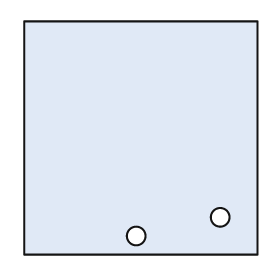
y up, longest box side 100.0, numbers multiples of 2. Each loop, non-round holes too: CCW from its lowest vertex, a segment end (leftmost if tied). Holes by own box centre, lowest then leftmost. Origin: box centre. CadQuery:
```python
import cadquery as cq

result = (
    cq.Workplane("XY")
    .moveTo(-50.0, -50.0)
    .lineTo(50.0, -50.0)
    .lineTo(50.0, 50.0)
    .lineTo(-50.0, 50.0)
    .close()
    .moveTo(-2.0, -42.0)
    .circle(4.0)
    .moveTo(34.0, -34.0)
    .circle(4.0)
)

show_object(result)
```